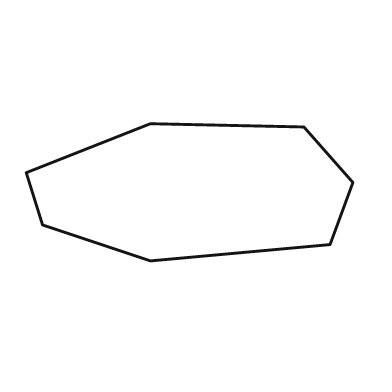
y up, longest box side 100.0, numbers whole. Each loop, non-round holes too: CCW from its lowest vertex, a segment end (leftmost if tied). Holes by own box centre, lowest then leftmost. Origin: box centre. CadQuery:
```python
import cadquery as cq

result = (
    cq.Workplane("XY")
    .moveTo(-12.0, -21.0)
    .lineTo(43.0, -16.0)
    .lineTo(50.0, 3.0)
    .lineTo(35.0, 20.0)
    .lineTo(-12.0, 21.0)
    .lineTo(-50.0, 6.0)
    .lineTo(-45.0, -10.0)
    .close()
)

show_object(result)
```